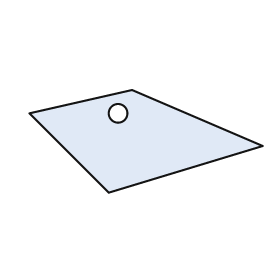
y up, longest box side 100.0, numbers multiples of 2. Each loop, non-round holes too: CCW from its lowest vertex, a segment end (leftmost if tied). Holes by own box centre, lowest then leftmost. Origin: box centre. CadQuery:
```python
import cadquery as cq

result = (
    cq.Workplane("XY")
    .moveTo(-16.0, -22.0)
    .lineTo(50.0, -2.0)
    .lineTo(-6.0, 22.0)
    .lineTo(-50.0, 12.0)
    .close()
    .moveTo(-12.0, 12.0)
    .circle(4.0)
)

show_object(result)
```